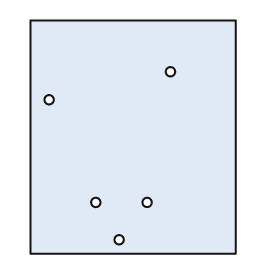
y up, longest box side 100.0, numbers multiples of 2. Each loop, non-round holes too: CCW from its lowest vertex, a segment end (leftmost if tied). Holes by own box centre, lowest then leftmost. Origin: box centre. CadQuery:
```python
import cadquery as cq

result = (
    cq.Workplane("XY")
    .moveTo(-44.0, -50.0)
    .lineTo(44.0, -50.0)
    .lineTo(44.0, 50.0)
    .lineTo(-44.0, 50.0)
    .close()
    .moveTo(-6.0, -44.0)
    .circle(2.0)
    .moveTo(-16.0, -28.0)
    .circle(2.0)
    .moveTo(6.0, -28.0)
    .circle(2.0)
    .moveTo(-36.0, 16.0)
    .circle(2.0)
    .moveTo(16.0, 28.0)
    .circle(2.0)
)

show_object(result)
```